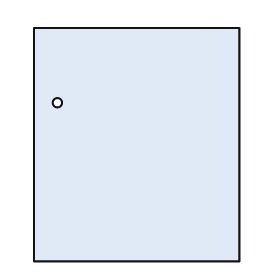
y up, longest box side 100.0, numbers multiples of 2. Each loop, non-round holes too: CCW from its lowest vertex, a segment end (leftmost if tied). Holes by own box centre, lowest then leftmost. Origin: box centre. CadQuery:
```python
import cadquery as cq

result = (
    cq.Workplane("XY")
    .moveTo(-44.0, -50.0)
    .lineTo(44.0, -50.0)
    .lineTo(44.0, 50.0)
    .lineTo(-44.0, 50.0)
    .close()
    .moveTo(-34.0, 18.0)
    .circle(2.0)
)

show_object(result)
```